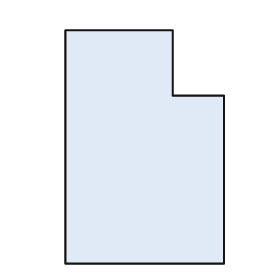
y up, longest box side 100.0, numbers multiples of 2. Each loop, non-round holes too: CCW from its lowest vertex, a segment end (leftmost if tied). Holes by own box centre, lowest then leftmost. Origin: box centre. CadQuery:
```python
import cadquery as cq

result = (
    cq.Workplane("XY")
    .moveTo(-34.0, -50.0)
    .lineTo(34.0, -50.0)
    .lineTo(34.0, 22.0)
    .lineTo(12.0, 22.0)
    .lineTo(12.0, 50.0)
    .lineTo(-34.0, 50.0)
    .close()
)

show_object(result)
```